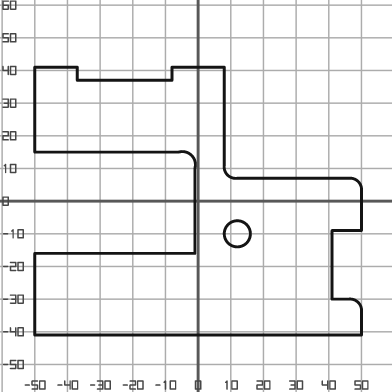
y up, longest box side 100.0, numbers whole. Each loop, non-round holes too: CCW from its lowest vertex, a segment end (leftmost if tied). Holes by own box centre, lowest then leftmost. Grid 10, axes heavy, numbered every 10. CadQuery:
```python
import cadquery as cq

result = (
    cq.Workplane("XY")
    .moveTo(-50.0, -41.0)
    .lineTo(50.0, -41.0)
    .lineTo(50.0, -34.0)
    .threePointArc((49.0, -31.0), (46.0, -30.0))
    .lineTo(41.0, -30.0)
    .lineTo(41.0, -9.0)
    .lineTo(50.0, -9.0)
    .lineTo(50.0, 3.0)
    .threePointArc((49.0, 6.0), (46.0, 7.0))
    .lineTo(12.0, 7.0)
    .threePointArc((9.0, 8.0), (8.0, 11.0))
    .lineTo(8.0, 41.0)
    .lineTo(-8.0, 41.0)
    .lineTo(-8.0, 37.0)
    .lineTo(-37.0, 37.0)
    .lineTo(-37.0, 41.0)
    .lineTo(-50.0, 41.0)
    .lineTo(-50.0, 15.0)
    .lineTo(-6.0, 15.0)
    .threePointArc((-2.0, 14.0), (-1.0, 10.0))
    .lineTo(-1.0, -16.0)
    .lineTo(-50.0, -16.0)
    .close()
    .moveTo(12.0, -10.0)
    .circle(4.0)
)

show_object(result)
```